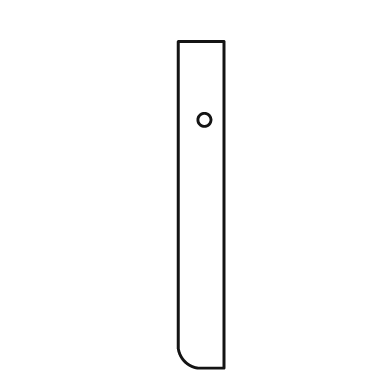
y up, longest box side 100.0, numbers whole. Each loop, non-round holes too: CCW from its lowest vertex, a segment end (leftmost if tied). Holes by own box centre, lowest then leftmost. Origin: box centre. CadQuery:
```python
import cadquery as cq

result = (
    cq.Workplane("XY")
    .moveTo(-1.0, -50.0)
    .lineTo(7.0, -50.0)
    .lineTo(7.0, 50.0)
    .lineTo(-7.0, 50.0)
    .lineTo(-7.0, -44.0)
    .threePointArc((-5.0, -48.0), (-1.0, -50.0))
    .close()
    .moveTo(1.0, 26.0)
    .circle(2.0)
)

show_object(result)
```